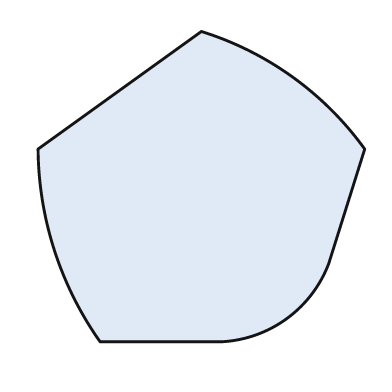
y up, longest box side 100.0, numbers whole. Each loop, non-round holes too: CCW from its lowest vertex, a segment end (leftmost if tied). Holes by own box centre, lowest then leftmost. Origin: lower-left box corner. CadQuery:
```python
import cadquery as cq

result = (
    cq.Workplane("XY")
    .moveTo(19.0, 0.0)
    .lineTo(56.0, 0.0)
    .threePointArc((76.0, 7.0), (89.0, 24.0))
    .lineTo(100.0, 59.0)
    .threePointArc((78.0, 81.0), (50.0, 95.0))
    .lineTo(0.0, 59.0)
    .threePointArc((5.0, 28.0), (19.0, 0.0))
    .close()
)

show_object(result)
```